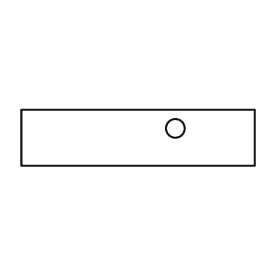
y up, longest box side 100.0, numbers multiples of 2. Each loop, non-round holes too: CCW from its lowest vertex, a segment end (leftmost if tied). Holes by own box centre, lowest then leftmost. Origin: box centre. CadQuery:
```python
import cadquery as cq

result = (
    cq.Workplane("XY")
    .moveTo(-50.0, -12.0)
    .lineTo(50.0, -12.0)
    .lineTo(50.0, 12.0)
    .lineTo(-50.0, 12.0)
    .close()
    .moveTo(16.0, 4.0)
    .circle(4.0)
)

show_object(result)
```